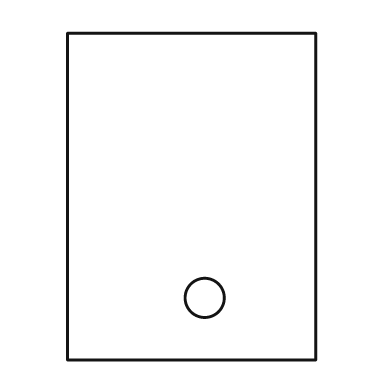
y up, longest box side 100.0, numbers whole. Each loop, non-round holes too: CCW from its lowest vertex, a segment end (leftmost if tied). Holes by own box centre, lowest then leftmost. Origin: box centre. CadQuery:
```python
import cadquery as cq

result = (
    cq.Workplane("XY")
    .moveTo(-38.0, -50.0)
    .lineTo(38.0, -50.0)
    .lineTo(38.0, 50.0)
    .lineTo(-38.0, 50.0)
    .close()
    .moveTo(4.0, -31.0)
    .circle(6.0)
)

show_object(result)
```